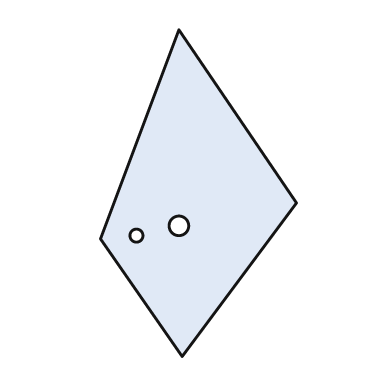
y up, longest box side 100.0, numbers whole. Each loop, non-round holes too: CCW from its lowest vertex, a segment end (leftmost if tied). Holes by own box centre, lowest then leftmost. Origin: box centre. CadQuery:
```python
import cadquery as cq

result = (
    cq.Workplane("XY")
    .moveTo(-5.0, -50.0)
    .lineTo(30.0, -3.0)
    .lineTo(-6.0, 50.0)
    .lineTo(-30.0, -14.0)
    .close()
    .moveTo(-19.0, -13.0)
    .circle(2.0)
    .moveTo(-6.0, -10.0)
    .circle(3.0)
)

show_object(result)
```